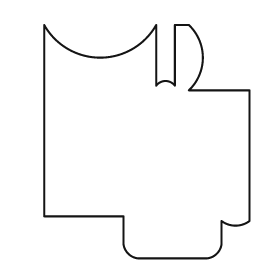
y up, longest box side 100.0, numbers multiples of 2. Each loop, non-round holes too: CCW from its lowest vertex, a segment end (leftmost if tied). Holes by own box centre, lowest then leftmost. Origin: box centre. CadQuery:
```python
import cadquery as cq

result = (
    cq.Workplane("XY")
    .moveTo(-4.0, -50.0)
    .lineTo(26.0, -50.0)
    .threePointArc((30.0, -48.0), (32.0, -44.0))
    .lineTo(32.0, -34.0)
    .threePointArc((38.0, -36.0), (44.0, -34.0))
    .lineTo(44.0, 22.0)
    .lineTo(18.0, 22.0)
    .threePointArc((24.0, 36.0), (18.0, 50.0))
    .lineTo(12.0, 50.0)
    .lineTo(12.0, 24.0)
    .threePointArc((8.0, 26.0), (4.0, 24.0))
    .lineTo(4.0, 50.0)
    .threePointArc((-20.0, 36.0), (-44.0, 50.0))
    .lineTo(-44.0, -32.0)
    .lineTo(-10.0, -32.0)
    .lineTo(-10.0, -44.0)
    .threePointArc((-8.0, -48.0), (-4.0, -50.0))
    .close()
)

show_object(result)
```